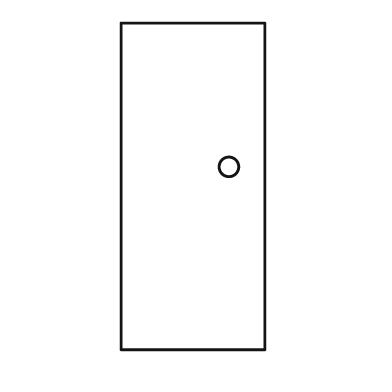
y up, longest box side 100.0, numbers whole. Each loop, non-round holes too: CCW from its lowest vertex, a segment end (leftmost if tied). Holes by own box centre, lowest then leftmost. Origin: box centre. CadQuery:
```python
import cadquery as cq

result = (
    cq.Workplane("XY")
    .moveTo(-22.0, -50.0)
    .lineTo(22.0, -50.0)
    .lineTo(22.0, 50.0)
    .lineTo(-22.0, 50.0)
    .close()
    .moveTo(11.0, 6.0)
    .circle(3.0)
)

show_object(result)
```